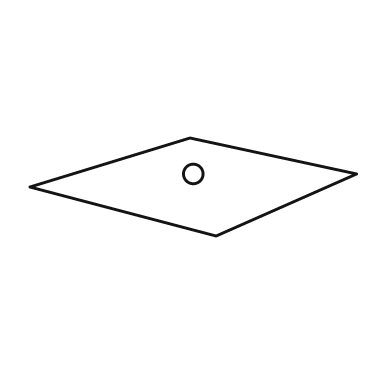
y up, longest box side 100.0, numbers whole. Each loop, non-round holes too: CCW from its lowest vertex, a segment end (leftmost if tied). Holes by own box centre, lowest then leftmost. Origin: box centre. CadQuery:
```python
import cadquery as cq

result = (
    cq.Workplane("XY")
    .moveTo(7.0, -15.0)
    .lineTo(50.0, 4.0)
    .lineTo(-1.0, 15.0)
    .lineTo(-50.0, 0.0)
    .close()
    .moveTo(0.0, 4.0)
    .circle(3.0)
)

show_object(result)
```